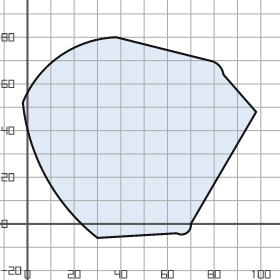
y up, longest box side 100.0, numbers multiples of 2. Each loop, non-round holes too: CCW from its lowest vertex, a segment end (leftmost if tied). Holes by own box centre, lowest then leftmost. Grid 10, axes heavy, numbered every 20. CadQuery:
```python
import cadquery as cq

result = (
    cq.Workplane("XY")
    .moveTo(30.0, -6.0)
    .lineTo(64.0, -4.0)
    .threePointArc((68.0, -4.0), (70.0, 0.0))
    .lineTo(98.0, 48.0)
    .lineTo(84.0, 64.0)
    .threePointArc((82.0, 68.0), (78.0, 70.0))
    .lineTo(38.0, 80.0)
    .threePointArc((14.0, 72.0), (-2.0, 52.0))
    .threePointArc((8.0, 20.0), (30.0, -6.0))
    .close()
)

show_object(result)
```